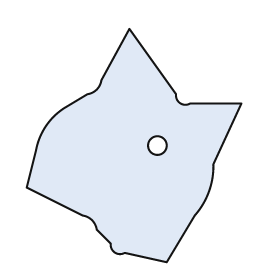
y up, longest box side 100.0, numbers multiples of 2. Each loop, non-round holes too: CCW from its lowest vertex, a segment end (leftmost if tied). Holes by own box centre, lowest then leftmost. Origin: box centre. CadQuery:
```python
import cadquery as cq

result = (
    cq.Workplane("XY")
    .moveTo(14.0, -50.0)
    .lineTo(26.0, -30.0)
    .threePointArc((32.0, -20.0), (34.0, -8.0))
    .lineTo(46.0, 18.0)
    .lineTo(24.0, 18.0)
    .threePointArc((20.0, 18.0), (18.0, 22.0))
    .lineTo(-2.0, 50.0)
    .lineTo(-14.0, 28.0)
    .threePointArc((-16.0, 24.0), (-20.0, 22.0))
    .lineTo(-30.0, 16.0)
    .threePointArc((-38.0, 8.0), (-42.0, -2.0))
    .lineTo(-46.0, -18.0)
    .lineTo(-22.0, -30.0)
    .threePointArc((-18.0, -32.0), (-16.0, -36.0))
    .lineTo(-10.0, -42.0)
    .threePointArc((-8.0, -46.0), (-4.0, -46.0))
    .close()
    .moveTo(10.0, 0.0)
    .circle(4.0)
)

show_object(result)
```